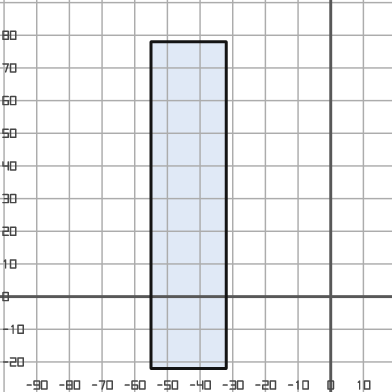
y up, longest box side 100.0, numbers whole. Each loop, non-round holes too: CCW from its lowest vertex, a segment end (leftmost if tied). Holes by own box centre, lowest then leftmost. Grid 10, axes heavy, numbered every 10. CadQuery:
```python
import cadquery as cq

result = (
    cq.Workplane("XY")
    .moveTo(-55.0, -22.0)
    .lineTo(-32.0, -22.0)
    .lineTo(-32.0, 78.0)
    .lineTo(-55.0, 78.0)
    .close()
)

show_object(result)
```